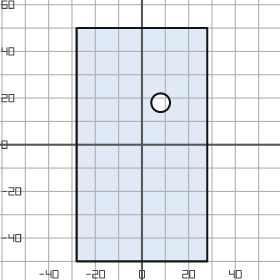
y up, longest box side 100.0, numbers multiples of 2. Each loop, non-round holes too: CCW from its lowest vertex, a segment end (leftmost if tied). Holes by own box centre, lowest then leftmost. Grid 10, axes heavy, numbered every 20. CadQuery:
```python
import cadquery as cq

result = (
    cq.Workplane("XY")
    .moveTo(-28.0, -50.0)
    .lineTo(28.0, -50.0)
    .lineTo(28.0, 50.0)
    .lineTo(-28.0, 50.0)
    .close()
    .moveTo(8.0, 18.0)
    .circle(4.0)
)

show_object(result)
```